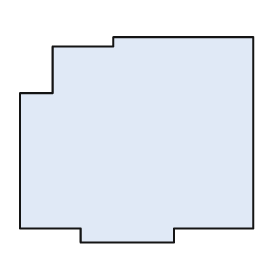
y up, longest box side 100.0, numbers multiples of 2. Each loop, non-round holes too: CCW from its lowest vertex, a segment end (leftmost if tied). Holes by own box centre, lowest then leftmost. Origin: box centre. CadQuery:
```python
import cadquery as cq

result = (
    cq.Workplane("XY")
    .moveTo(-24.0, -44.0)
    .lineTo(16.0, -44.0)
    .lineTo(16.0, -38.0)
    .lineTo(50.0, -38.0)
    .lineTo(50.0, 44.0)
    .lineTo(-10.0, 44.0)
    .lineTo(-10.0, 40.0)
    .lineTo(-36.0, 40.0)
    .lineTo(-36.0, 20.0)
    .lineTo(-50.0, 20.0)
    .lineTo(-50.0, -38.0)
    .lineTo(-24.0, -38.0)
    .close()
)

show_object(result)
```